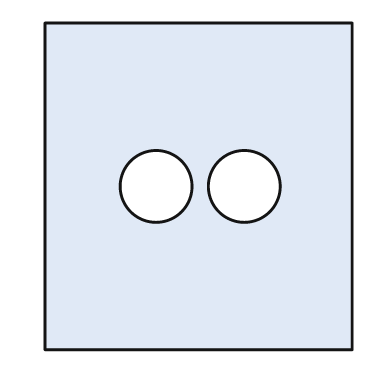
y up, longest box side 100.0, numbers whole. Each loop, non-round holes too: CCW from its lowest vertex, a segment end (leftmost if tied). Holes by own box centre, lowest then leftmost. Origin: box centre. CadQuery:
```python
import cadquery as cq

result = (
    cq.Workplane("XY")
    .moveTo(-47.0, -50.0)
    .lineTo(47.0, -50.0)
    .lineTo(47.0, 50.0)
    .lineTo(-47.0, 50.0)
    .close()
    .moveTo(-13.0, 0.0)
    .circle(11.0)
    .moveTo(14.0, 0.0)
    .circle(11.0)
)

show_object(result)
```